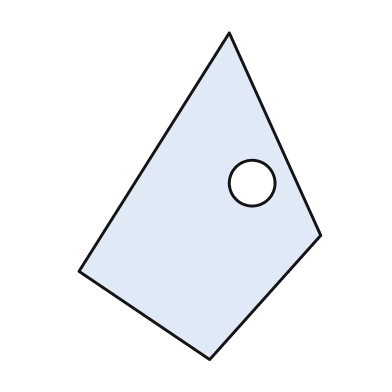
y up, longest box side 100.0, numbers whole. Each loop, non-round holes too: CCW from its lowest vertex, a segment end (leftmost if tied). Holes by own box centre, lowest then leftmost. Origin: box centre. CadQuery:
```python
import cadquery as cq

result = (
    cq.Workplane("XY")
    .moveTo(3.0, -50.0)
    .lineTo(37.0, -12.0)
    .lineTo(9.0, 50.0)
    .lineTo(-37.0, -23.0)
    .close()
    .moveTo(16.0, 4.0)
    .circle(7.0)
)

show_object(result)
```